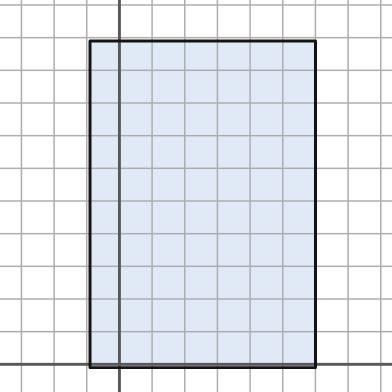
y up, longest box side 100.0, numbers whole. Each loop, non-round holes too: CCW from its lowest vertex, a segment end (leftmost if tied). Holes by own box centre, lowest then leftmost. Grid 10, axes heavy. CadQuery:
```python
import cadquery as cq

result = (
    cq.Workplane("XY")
    .moveTo(-9.0, -1.0)
    .lineTo(60.0, -1.0)
    .lineTo(60.0, 99.0)
    .lineTo(-9.0, 99.0)
    .close()
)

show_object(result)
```